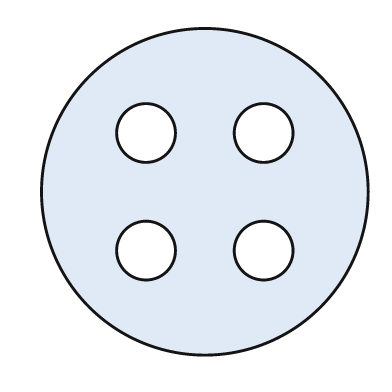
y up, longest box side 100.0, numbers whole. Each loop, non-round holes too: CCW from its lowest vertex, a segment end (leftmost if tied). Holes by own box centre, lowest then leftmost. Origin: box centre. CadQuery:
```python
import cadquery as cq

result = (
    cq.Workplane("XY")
    .moveTo(0.0, 0.0)
    .circle(50.0)
    .moveTo(-18.0, -18.0)
    .circle(9.0)
    .moveTo(18.0, -18.0)
    .circle(9.0)
    .moveTo(-18.0, 18.0)
    .circle(9.0)
    .moveTo(18.0, 18.0)
    .circle(9.0)
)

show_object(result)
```